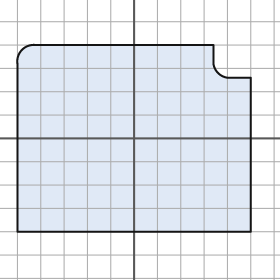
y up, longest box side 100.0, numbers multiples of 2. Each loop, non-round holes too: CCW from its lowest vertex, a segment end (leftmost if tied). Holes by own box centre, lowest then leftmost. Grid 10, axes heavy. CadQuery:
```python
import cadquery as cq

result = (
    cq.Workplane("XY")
    .moveTo(-50.0, -40.0)
    .lineTo(50.0, -40.0)
    .lineTo(50.0, 26.0)
    .lineTo(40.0, 26.0)
    .threePointArc((36.0, 28.0), (34.0, 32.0))
    .lineTo(34.0, 40.0)
    .lineTo(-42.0, 40.0)
    .threePointArc((-48.0, 38.0), (-50.0, 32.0))
    .close()
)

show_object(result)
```